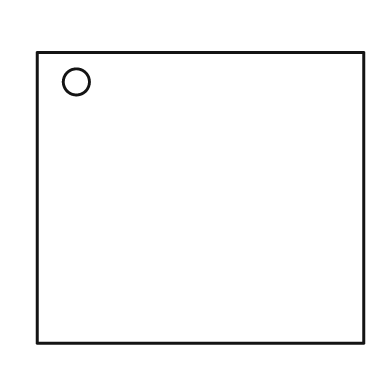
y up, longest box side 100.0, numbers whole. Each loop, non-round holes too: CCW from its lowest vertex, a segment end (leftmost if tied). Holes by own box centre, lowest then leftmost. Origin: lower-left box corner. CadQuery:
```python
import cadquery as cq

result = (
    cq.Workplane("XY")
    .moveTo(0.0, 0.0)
    .lineTo(100.0, 0.0)
    .lineTo(100.0, 89.0)
    .lineTo(0.0, 89.0)
    .close()
    .moveTo(12.0, 80.0)
    .circle(4.0)
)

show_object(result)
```